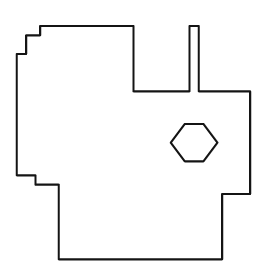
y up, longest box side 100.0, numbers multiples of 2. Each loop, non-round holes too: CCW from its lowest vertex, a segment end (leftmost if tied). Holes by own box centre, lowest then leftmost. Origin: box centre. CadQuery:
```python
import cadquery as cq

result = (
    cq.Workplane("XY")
    .moveTo(-32.0, -50.0)
    .lineTo(38.0, -50.0)
    .lineTo(38.0, -22.0)
    .lineTo(50.0, -22.0)
    .lineTo(50.0, 22.0)
    .lineTo(28.0, 22.0)
    .lineTo(28.0, 50.0)
    .lineTo(24.0, 50.0)
    .lineTo(24.0, 22.0)
    .lineTo(0.0, 22.0)
    .lineTo(0.0, 50.0)
    .lineTo(-40.0, 50.0)
    .lineTo(-40.0, 46.0)
    .lineTo(-46.0, 46.0)
    .lineTo(-46.0, 38.0)
    .lineTo(-50.0, 38.0)
    .lineTo(-50.0, -14.0)
    .lineTo(-42.0, -14.0)
    .lineTo(-42.0, -18.0)
    .lineTo(-32.0, -18.0)
    .close()
    .moveTo(22.0, -8.0)
    .lineTo(30.0, -8.0)
    .lineTo(36.0, 0.0)
    .lineTo(30.0, 8.0)
    .lineTo(22.0, 8.0)
    .lineTo(16.0, 0.0)
    .close()
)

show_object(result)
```